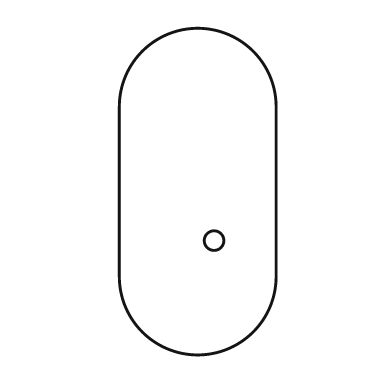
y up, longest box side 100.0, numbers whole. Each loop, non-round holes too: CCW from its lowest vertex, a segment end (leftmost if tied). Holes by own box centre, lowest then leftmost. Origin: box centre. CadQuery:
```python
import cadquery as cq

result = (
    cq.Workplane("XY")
    .moveTo(-24.0, -26.0)
    .threePointArc((0.0, -50.0), (24.0, -26.0))
    .lineTo(24.0, 26.0)
    .threePointArc((0.0, 50.0), (-24.0, 26.0))
    .close()
    .moveTo(5.0, -15.0)
    .circle(3.0)
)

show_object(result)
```